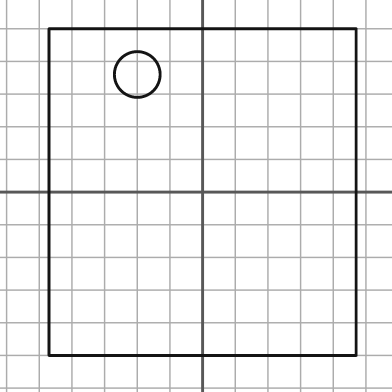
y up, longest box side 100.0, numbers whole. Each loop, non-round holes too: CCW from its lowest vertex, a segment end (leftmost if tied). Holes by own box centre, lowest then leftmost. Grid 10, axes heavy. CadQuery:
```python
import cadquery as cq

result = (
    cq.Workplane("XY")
    .moveTo(-47.0, -50.0)
    .lineTo(47.0, -50.0)
    .lineTo(47.0, 50.0)
    .lineTo(-47.0, 50.0)
    .close()
    .moveTo(-20.0, 36.0)
    .circle(7.0)
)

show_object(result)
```